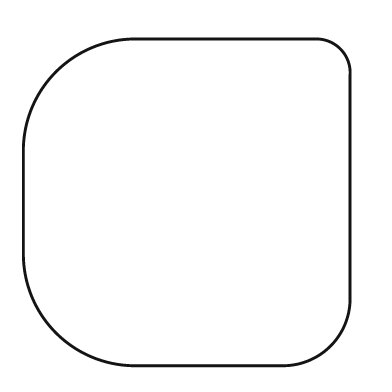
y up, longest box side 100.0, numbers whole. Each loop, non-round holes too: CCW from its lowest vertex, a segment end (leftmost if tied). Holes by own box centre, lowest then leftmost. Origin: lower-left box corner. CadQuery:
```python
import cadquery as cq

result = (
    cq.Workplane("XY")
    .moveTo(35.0, 0.0)
    .lineTo(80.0, 0.0)
    .threePointArc((94.0, 6.0), (100.0, 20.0))
    .lineTo(100.0, 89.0)
    .threePointArc((97.0, 97.0), (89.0, 100.0))
    .lineTo(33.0, 100.0)
    .threePointArc((10.0, 90.0), (0.0, 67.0))
    .lineTo(0.0, 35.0)
    .threePointArc((10.0, 10.0), (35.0, 0.0))
    .close()
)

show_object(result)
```